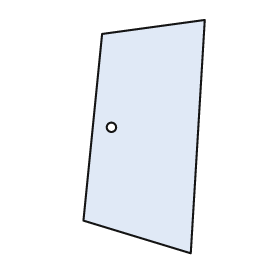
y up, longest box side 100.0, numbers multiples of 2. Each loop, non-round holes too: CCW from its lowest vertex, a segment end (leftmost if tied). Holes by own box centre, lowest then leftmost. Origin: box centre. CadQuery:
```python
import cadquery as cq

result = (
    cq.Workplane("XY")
    .moveTo(20.0, -50.0)
    .lineTo(26.0, 50.0)
    .lineTo(-18.0, 44.0)
    .lineTo(-26.0, -36.0)
    .close()
    .moveTo(-14.0, 4.0)
    .circle(2.0)
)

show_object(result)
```